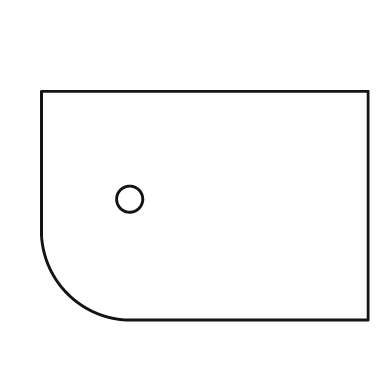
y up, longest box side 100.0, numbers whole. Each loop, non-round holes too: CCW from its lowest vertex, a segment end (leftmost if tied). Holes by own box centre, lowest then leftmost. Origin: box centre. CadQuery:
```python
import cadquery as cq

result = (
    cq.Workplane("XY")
    .moveTo(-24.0, -35.0)
    .lineTo(50.0, -35.0)
    .lineTo(50.0, 35.0)
    .lineTo(-50.0, 35.0)
    .lineTo(-50.0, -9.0)
    .threePointArc((-42.0, -27.0), (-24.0, -35.0))
    .close()
    .moveTo(-23.0, 2.0)
    .circle(4.0)
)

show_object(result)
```